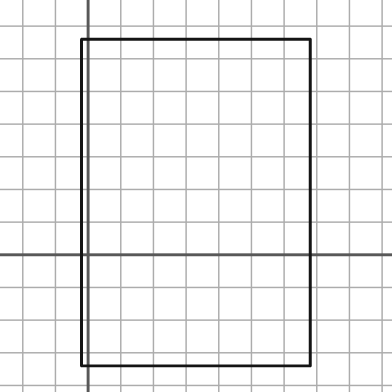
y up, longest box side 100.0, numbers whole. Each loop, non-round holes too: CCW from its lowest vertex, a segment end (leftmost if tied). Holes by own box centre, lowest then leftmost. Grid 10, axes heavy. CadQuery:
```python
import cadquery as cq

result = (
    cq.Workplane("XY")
    .moveTo(-2.0, -34.0)
    .lineTo(68.0, -34.0)
    .lineTo(68.0, 66.0)
    .lineTo(-2.0, 66.0)
    .close()
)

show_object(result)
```